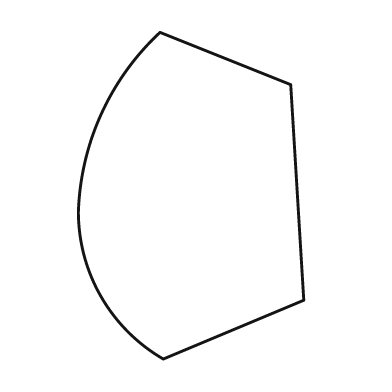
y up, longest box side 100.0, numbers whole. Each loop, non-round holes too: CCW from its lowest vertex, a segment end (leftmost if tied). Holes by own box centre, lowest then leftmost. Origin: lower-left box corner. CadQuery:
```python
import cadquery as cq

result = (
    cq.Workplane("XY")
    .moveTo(26.0, 0.0)
    .lineTo(69.0, 18.0)
    .lineTo(65.0, 84.0)
    .lineTo(25.0, 100.0)
    .threePointArc((7.0, 75.0), (0.0, 45.0))
    .threePointArc((7.0, 19.0), (26.0, 0.0))
    .close()
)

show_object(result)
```